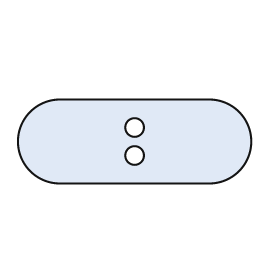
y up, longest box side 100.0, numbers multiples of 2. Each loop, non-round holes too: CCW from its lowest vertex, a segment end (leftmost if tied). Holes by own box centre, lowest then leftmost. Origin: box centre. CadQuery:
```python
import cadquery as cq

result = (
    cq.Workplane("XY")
    .moveTo(-32.0, -18.0)
    .lineTo(32.0, -18.0)
    .threePointArc((50.0, 0.0), (32.0, 18.0))
    .lineTo(-32.0, 18.0)
    .threePointArc((-50.0, 0.0), (-32.0, -18.0))
    .close()
    .moveTo(0.0, -6.0)
    .circle(4.0)
    .moveTo(0.0, 6.0)
    .circle(4.0)
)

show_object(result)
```